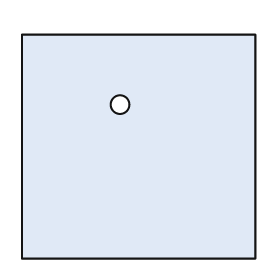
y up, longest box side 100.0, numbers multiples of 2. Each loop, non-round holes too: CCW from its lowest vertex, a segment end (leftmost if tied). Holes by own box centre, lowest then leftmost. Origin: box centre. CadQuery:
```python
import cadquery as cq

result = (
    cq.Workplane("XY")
    .moveTo(-50.0, -48.0)
    .lineTo(50.0, -48.0)
    .lineTo(50.0, 48.0)
    .lineTo(-50.0, 48.0)
    .close()
    .moveTo(-8.0, 18.0)
    .circle(4.0)
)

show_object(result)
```